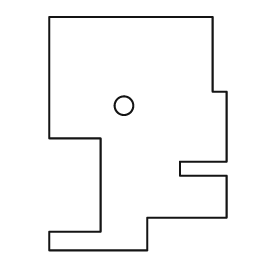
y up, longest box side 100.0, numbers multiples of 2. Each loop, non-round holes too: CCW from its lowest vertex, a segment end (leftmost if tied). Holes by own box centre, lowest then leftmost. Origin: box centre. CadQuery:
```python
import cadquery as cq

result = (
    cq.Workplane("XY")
    .moveTo(-38.0, -50.0)
    .lineTo(4.0, -50.0)
    .lineTo(4.0, -36.0)
    .lineTo(38.0, -36.0)
    .lineTo(38.0, -18.0)
    .lineTo(18.0, -18.0)
    .lineTo(18.0, -12.0)
    .lineTo(38.0, -12.0)
    .lineTo(38.0, 18.0)
    .lineTo(32.0, 18.0)
    .lineTo(32.0, 50.0)
    .lineTo(-38.0, 50.0)
    .lineTo(-38.0, -2.0)
    .lineTo(-16.0, -2.0)
    .lineTo(-16.0, -42.0)
    .lineTo(-38.0, -42.0)
    .close()
    .moveTo(-6.0, 12.0)
    .circle(4.0)
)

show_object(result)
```